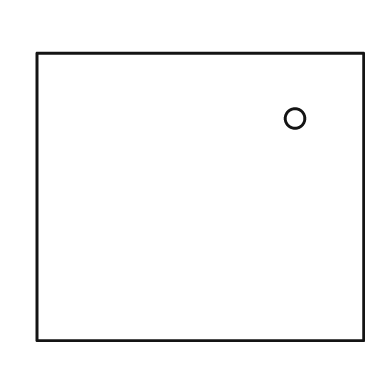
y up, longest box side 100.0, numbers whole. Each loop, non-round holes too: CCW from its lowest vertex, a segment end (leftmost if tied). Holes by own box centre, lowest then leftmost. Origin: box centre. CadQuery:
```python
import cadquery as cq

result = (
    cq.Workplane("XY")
    .moveTo(-50.0, -44.0)
    .lineTo(50.0, -44.0)
    .lineTo(50.0, 44.0)
    .lineTo(-50.0, 44.0)
    .close()
    .moveTo(29.0, 24.0)
    .circle(3.0)
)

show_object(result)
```